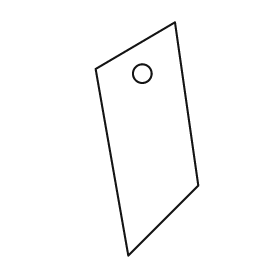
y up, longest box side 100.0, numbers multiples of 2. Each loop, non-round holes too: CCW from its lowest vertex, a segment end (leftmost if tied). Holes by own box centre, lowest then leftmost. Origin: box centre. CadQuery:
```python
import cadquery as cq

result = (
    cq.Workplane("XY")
    .moveTo(-8.0, -50.0)
    .lineTo(22.0, -20.0)
    .lineTo(12.0, 50.0)
    .lineTo(-22.0, 30.0)
    .close()
    .moveTo(-2.0, 28.0)
    .circle(4.0)
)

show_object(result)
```